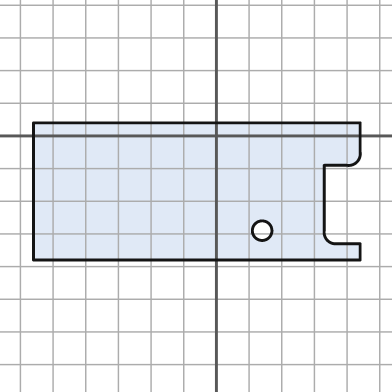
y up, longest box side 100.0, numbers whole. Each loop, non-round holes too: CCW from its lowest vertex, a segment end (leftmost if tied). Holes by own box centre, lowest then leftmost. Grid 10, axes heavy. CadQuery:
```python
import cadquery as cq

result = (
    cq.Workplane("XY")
    .moveTo(-56.0, -38.0)
    .lineTo(44.0, -38.0)
    .lineTo(44.0, -33.0)
    .lineTo(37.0, -33.0)
    .threePointArc((34.0, -32.0), (33.0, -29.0))
    .lineTo(33.0, -9.0)
    .lineTo(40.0, -9.0)
    .threePointArc((43.0, -8.0), (44.0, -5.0))
    .lineTo(44.0, 4.0)
    .lineTo(-56.0, 4.0)
    .close()
    .moveTo(14.0, -29.0)
    .circle(3.0)
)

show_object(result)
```